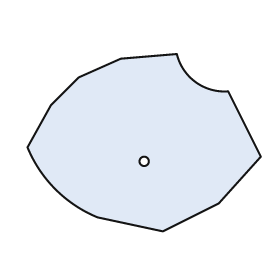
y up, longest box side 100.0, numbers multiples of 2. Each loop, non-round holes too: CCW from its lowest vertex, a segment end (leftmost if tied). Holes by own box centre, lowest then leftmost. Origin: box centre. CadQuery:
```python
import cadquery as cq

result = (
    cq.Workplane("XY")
    .moveTo(8.0, -38.0)
    .lineTo(32.0, -26.0)
    .lineTo(50.0, -6.0)
    .lineTo(36.0, 22.0)
    .threePointArc((22.0, 26.0), (14.0, 38.0))
    .lineTo(-10.0, 36.0)
    .lineTo(-28.0, 28.0)
    .lineTo(-40.0, 16.0)
    .lineTo(-50.0, -2.0)
    .threePointArc((-38.0, -20.0), (-20.0, -32.0))
    .close()
    .moveTo(0.0, -8.0)
    .circle(2.0)
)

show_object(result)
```